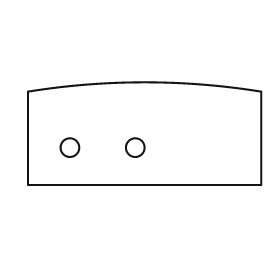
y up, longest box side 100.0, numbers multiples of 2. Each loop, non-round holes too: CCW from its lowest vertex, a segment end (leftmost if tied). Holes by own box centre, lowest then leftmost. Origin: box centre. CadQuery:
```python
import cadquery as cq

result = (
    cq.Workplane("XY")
    .moveTo(-50.0, -22.0)
    .lineTo(50.0, -22.0)
    .lineTo(50.0, 18.0)
    .threePointArc((0.0, 22.0), (-50.0, 18.0))
    .close()
    .moveTo(-32.0, -6.0)
    .circle(4.0)
    .moveTo(-4.0, -6.0)
    .circle(4.0)
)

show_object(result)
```